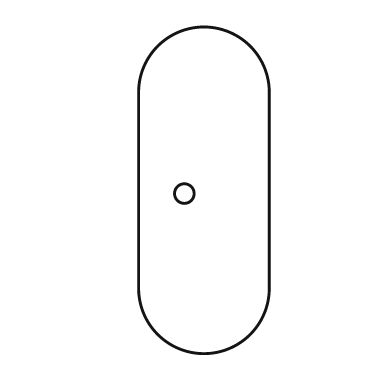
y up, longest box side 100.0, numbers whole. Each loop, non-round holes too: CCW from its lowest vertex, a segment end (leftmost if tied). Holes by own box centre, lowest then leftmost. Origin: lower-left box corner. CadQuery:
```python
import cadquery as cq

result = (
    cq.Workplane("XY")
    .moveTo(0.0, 20.0)
    .threePointArc((20.0, 0.0), (40.0, 20.0))
    .lineTo(40.0, 80.0)
    .threePointArc((20.0, 100.0), (0.0, 80.0))
    .close()
    .moveTo(14.0, 49.0)
    .circle(3.0)
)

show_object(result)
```